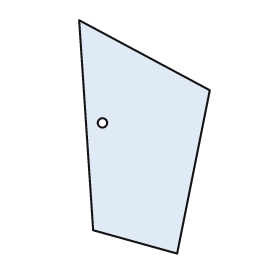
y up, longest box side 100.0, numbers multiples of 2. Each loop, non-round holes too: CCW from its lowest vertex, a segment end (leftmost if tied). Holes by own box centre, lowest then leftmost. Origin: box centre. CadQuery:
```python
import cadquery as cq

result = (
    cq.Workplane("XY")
    .moveTo(14.0, -50.0)
    .lineTo(28.0, 20.0)
    .lineTo(-28.0, 50.0)
    .lineTo(-22.0, -40.0)
    .close()
    .moveTo(-18.0, 6.0)
    .circle(2.0)
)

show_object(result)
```